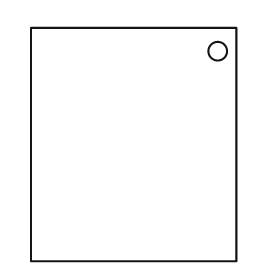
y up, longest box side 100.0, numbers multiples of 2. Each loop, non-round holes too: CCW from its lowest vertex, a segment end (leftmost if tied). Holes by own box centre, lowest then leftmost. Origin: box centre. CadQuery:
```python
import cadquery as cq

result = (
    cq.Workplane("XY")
    .moveTo(-44.0, -50.0)
    .lineTo(44.0, -50.0)
    .lineTo(44.0, 50.0)
    .lineTo(-44.0, 50.0)
    .close()
    .moveTo(36.0, 40.0)
    .circle(4.0)
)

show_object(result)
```